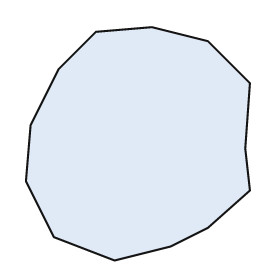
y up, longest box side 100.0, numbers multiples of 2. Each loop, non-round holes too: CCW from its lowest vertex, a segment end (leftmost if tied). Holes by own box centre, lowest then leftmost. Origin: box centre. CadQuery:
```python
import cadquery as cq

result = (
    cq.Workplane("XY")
    .moveTo(-10.0, -50.0)
    .lineTo(14.0, -44.0)
    .lineTo(30.0, -36.0)
    .lineTo(48.0, -20.0)
    .lineTo(46.0, -2.0)
    .lineTo(48.0, 26.0)
    .lineTo(30.0, 44.0)
    .lineTo(6.0, 50.0)
    .lineTo(-18.0, 48.0)
    .lineTo(-34.0, 32.0)
    .lineTo(-46.0, 8.0)
    .lineTo(-48.0, -16.0)
    .lineTo(-36.0, -40.0)
    .close()
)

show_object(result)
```